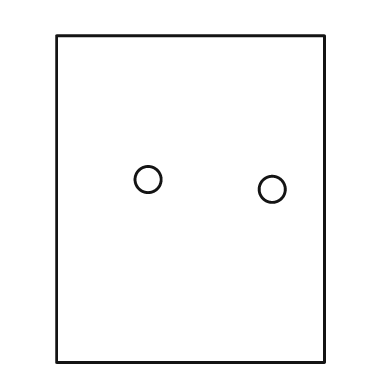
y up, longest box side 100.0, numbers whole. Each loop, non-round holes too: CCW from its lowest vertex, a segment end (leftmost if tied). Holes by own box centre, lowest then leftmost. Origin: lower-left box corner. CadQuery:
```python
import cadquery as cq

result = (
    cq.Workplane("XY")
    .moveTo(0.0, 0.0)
    .lineTo(82.0, 0.0)
    .lineTo(82.0, 100.0)
    .lineTo(0.0, 100.0)
    .close()
    .moveTo(66.0, 53.0)
    .circle(4.0)
    .moveTo(28.0, 56.0)
    .circle(4.0)
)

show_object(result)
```